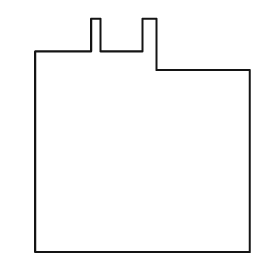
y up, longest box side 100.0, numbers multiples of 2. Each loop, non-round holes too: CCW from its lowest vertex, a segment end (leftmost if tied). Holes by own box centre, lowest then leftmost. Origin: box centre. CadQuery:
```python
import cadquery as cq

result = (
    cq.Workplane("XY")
    .moveTo(-46.0, -50.0)
    .lineTo(46.0, -50.0)
    .lineTo(46.0, 28.0)
    .lineTo(6.0, 28.0)
    .lineTo(6.0, 50.0)
    .lineTo(0.0, 50.0)
    .lineTo(0.0, 36.0)
    .lineTo(-18.0, 36.0)
    .lineTo(-18.0, 50.0)
    .lineTo(-22.0, 50.0)
    .lineTo(-22.0, 36.0)
    .lineTo(-46.0, 36.0)
    .close()
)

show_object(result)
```